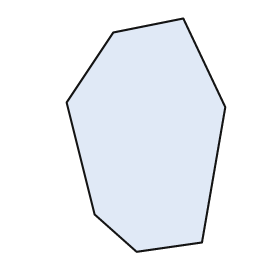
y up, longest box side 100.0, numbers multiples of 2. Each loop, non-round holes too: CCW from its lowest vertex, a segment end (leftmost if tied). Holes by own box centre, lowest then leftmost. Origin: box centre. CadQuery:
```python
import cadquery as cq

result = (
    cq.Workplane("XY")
    .moveTo(-4.0, -50.0)
    .lineTo(24.0, -46.0)
    .lineTo(34.0, 12.0)
    .lineTo(16.0, 50.0)
    .lineTo(-14.0, 44.0)
    .lineTo(-34.0, 14.0)
    .lineTo(-22.0, -34.0)
    .close()
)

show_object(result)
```